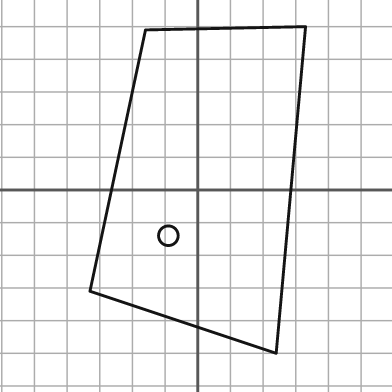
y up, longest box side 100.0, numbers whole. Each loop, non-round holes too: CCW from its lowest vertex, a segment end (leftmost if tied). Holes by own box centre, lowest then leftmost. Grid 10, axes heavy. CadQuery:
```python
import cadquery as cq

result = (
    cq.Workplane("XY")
    .moveTo(24.0, -50.0)
    .lineTo(33.0, 50.0)
    .lineTo(-16.0, 49.0)
    .lineTo(-33.0, -31.0)
    .close()
    .moveTo(-9.0, -14.0)
    .circle(3.0)
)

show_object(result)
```